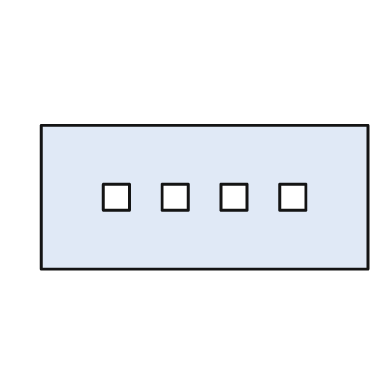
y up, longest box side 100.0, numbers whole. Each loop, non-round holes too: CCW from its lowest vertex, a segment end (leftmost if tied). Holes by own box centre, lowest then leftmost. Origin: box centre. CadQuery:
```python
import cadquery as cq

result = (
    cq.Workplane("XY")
    .moveTo(-50.0, -22.0)
    .lineTo(50.0, -22.0)
    .lineTo(50.0, 22.0)
    .lineTo(-50.0, 22.0)
    .close()
    .moveTo(-31.0, -4.0)
    .lineTo(-23.0, -4.0)
    .lineTo(-23.0, 4.0)
    .lineTo(-31.0, 4.0)
    .close()
    .moveTo(-13.0, -4.0)
    .lineTo(-5.0, -4.0)
    .lineTo(-5.0, 4.0)
    .lineTo(-13.0, 4.0)
    .close()
    .moveTo(5.0, -4.0)
    .lineTo(13.0, -4.0)
    .lineTo(13.0, 4.0)
    .lineTo(5.0, 4.0)
    .close()
    .moveTo(23.0, -4.0)
    .lineTo(31.0, -4.0)
    .lineTo(31.0, 4.0)
    .lineTo(23.0, 4.0)
    .close()
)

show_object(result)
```